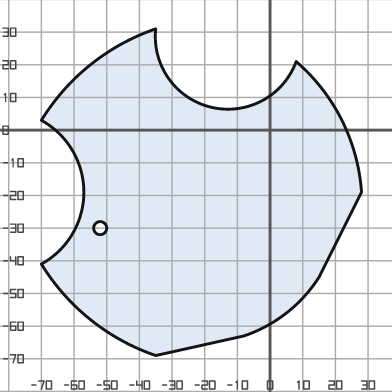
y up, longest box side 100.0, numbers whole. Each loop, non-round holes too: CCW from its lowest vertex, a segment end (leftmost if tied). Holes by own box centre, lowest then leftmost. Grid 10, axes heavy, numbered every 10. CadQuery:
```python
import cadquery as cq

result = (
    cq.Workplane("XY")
    .moveTo(-35.0, -69.0)
    .lineTo(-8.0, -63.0)
    .threePointArc((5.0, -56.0), (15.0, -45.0))
    .lineTo(28.0, -19.0)
    .threePointArc((22.0, 3.0), (8.0, 21.0))
    .threePointArc((-18.0, 7.0), (-35.0, 31.0))
    .threePointArc((-55.0, 20.0), (-70.0, 3.0))
    .threePointArc((-57.0, -19.0), (-70.0, -41.0))
    .threePointArc((-55.0, -58.0), (-35.0, -69.0))
    .close()
    .moveTo(-52.0, -30.0)
    .circle(2.0)
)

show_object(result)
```